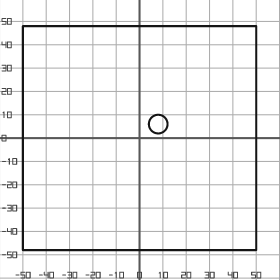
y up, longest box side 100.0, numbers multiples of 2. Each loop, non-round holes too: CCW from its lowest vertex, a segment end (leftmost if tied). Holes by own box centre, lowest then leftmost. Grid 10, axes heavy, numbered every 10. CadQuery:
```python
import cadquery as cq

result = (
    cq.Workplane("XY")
    .moveTo(-50.0, -48.0)
    .lineTo(50.0, -48.0)
    .lineTo(50.0, 48.0)
    .lineTo(-50.0, 48.0)
    .close()
    .moveTo(8.0, 6.0)
    .circle(4.0)
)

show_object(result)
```